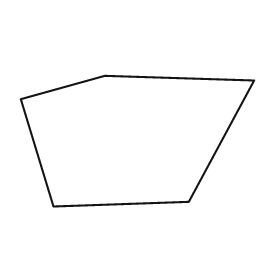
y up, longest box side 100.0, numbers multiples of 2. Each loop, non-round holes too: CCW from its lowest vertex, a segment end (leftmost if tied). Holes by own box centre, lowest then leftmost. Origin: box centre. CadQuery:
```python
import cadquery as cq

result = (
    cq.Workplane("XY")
    .moveTo(-36.0, -28.0)
    .lineTo(22.0, -26.0)
    .lineTo(50.0, 26.0)
    .lineTo(-14.0, 28.0)
    .lineTo(-50.0, 18.0)
    .close()
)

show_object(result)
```